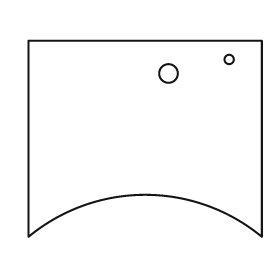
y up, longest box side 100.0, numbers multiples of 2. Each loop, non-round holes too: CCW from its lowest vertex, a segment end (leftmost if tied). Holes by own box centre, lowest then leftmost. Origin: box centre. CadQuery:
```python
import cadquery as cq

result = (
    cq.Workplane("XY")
    .moveTo(-50.0, -42.0)
    .threePointArc((0.0, -24.0), (50.0, -42.0))
    .lineTo(50.0, 42.0)
    .lineTo(-50.0, 42.0)
    .close()
    .moveTo(10.0, 28.0)
    .circle(4.0)
    .moveTo(36.0, 34.0)
    .circle(2.0)
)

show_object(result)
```